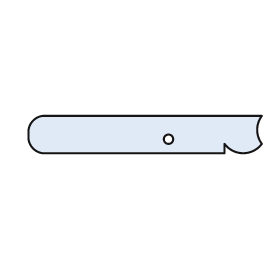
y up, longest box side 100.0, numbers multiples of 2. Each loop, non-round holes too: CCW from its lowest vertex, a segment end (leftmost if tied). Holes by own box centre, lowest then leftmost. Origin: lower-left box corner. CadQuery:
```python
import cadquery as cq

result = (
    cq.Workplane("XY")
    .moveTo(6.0, 0.0)
    .lineTo(84.0, 0.0)
    .lineTo(84.0, 4.0)
    .threePointArc((92.0, 0.0), (100.0, 4.0))
    .threePointArc((98.0, 10.0), (100.0, 16.0))
    .lineTo(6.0, 16.0)
    .threePointArc((2.0, 14.0), (0.0, 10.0))
    .lineTo(0.0, 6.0)
    .threePointArc((2.0, 2.0), (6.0, 0.0))
    .close()
    .moveTo(60.0, 6.0)
    .circle(2.0)
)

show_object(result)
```